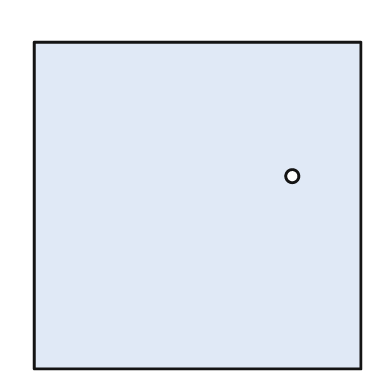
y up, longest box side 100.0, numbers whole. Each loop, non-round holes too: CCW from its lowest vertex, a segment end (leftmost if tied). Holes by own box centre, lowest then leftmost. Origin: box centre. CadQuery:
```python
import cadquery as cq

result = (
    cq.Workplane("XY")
    .moveTo(-50.0, -50.0)
    .lineTo(50.0, -50.0)
    .lineTo(50.0, 50.0)
    .lineTo(-50.0, 50.0)
    .close()
    .moveTo(29.0, 9.0)
    .circle(2.0)
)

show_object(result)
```